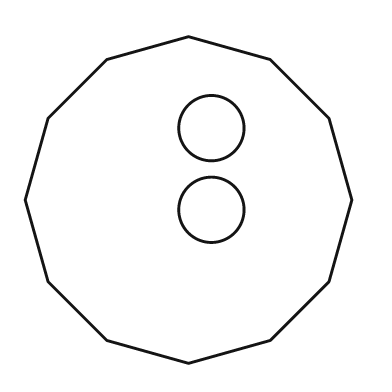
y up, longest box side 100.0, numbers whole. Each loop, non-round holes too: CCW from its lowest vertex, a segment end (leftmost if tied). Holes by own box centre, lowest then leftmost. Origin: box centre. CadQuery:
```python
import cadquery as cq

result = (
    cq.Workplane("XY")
    .moveTo(0.0, -50.0)
    .lineTo(25.0, -43.0)
    .lineTo(43.0, -25.0)
    .lineTo(50.0, 0.0)
    .lineTo(43.0, 25.0)
    .lineTo(25.0, 43.0)
    .lineTo(0.0, 50.0)
    .lineTo(-25.0, 43.0)
    .lineTo(-43.0, 25.0)
    .lineTo(-50.0, 0.0)
    .lineTo(-43.0, -25.0)
    .lineTo(-25.0, -43.0)
    .close()
    .moveTo(7.0, -3.0)
    .circle(10.0)
    .moveTo(7.0, 22.0)
    .circle(10.0)
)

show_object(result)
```